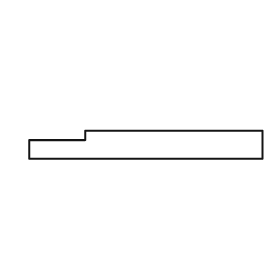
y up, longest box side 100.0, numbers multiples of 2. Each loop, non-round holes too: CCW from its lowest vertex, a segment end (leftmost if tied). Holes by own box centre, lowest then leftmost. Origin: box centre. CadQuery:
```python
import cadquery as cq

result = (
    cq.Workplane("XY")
    .moveTo(-50.0, -6.0)
    .lineTo(50.0, -6.0)
    .lineTo(50.0, 6.0)
    .lineTo(-26.0, 6.0)
    .lineTo(-26.0, 2.0)
    .lineTo(-50.0, 2.0)
    .close()
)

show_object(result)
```